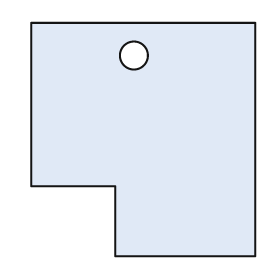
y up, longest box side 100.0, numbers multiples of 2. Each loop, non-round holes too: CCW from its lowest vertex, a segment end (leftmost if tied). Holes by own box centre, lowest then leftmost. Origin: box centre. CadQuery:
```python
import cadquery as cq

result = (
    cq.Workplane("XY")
    .moveTo(-12.0, -50.0)
    .lineTo(48.0, -50.0)
    .lineTo(48.0, 50.0)
    .lineTo(-48.0, 50.0)
    .lineTo(-48.0, -20.0)
    .lineTo(-12.0, -20.0)
    .close()
    .moveTo(-4.0, 36.0)
    .circle(6.0)
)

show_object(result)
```